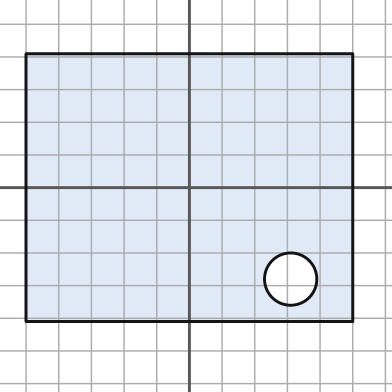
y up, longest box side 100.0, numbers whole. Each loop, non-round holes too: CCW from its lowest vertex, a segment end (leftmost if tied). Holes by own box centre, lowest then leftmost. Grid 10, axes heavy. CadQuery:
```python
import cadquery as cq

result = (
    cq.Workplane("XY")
    .moveTo(-50.0, -41.0)
    .lineTo(50.0, -41.0)
    .lineTo(50.0, 41.0)
    .lineTo(-50.0, 41.0)
    .close()
    .moveTo(31.0, -28.0)
    .circle(8.0)
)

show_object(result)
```